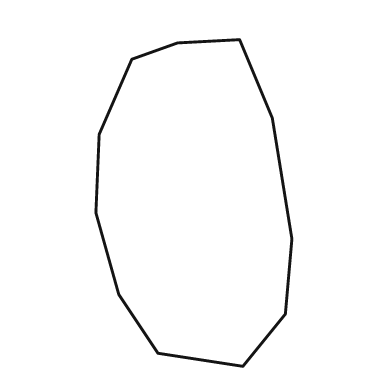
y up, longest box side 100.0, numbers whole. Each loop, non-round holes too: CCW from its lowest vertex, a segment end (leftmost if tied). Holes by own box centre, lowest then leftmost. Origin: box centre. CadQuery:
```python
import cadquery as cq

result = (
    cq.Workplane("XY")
    .moveTo(15.0, -50.0)
    .lineTo(28.0, -34.0)
    .lineTo(30.0, -11.0)
    .lineTo(24.0, 26.0)
    .lineTo(14.0, 50.0)
    .lineTo(-5.0, 49.0)
    .lineTo(-19.0, 44.0)
    .lineTo(-29.0, 21.0)
    .lineTo(-30.0, -3.0)
    .lineTo(-23.0, -28.0)
    .lineTo(-11.0, -46.0)
    .close()
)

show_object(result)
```